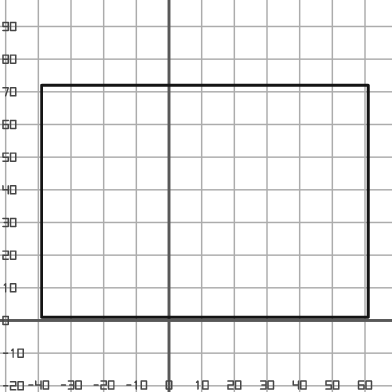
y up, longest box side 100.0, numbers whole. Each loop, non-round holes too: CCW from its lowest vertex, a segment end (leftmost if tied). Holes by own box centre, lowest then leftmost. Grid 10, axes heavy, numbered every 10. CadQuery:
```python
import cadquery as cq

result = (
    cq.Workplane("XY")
    .moveTo(-39.0, 1.0)
    .lineTo(61.0, 1.0)
    .lineTo(61.0, 72.0)
    .lineTo(-39.0, 72.0)
    .close()
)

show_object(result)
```